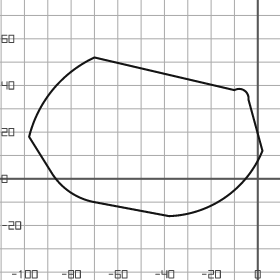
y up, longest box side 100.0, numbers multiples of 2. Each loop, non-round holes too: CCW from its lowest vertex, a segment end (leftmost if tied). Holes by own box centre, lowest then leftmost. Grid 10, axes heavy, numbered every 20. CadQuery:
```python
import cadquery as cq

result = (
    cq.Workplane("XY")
    .moveTo(-38.0, -16.0)
    .threePointArc((-14.0, -8.0), (2.0, 12.0))
    .lineTo(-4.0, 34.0)
    .threePointArc((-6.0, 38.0), (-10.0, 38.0))
    .lineTo(-70.0, 52.0)
    .threePointArc((-88.0, 38.0), (-98.0, 18.0))
    .lineTo(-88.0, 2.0)
    .threePointArc((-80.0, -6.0), (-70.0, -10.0))
    .close()
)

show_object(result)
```